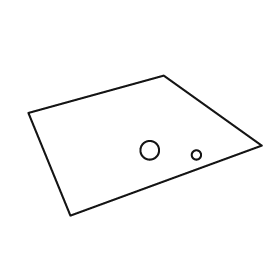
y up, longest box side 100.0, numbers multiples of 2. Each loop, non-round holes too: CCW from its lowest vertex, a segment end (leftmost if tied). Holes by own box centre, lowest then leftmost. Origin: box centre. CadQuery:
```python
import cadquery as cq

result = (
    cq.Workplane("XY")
    .moveTo(-32.0, -30.0)
    .lineTo(50.0, 0.0)
    .lineTo(8.0, 30.0)
    .lineTo(-50.0, 14.0)
    .close()
    .moveTo(22.0, -4.0)
    .circle(2.0)
    .moveTo(2.0, -2.0)
    .circle(4.0)
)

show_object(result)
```